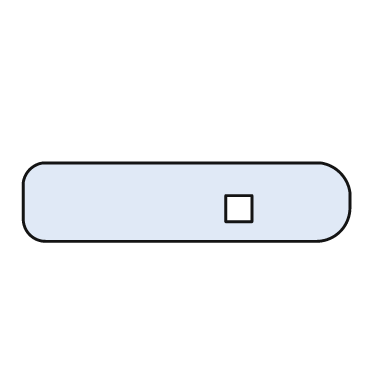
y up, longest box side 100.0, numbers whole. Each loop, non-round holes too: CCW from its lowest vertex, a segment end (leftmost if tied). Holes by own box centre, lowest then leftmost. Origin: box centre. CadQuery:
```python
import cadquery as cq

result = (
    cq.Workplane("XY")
    .moveTo(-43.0, -12.0)
    .lineTo(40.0, -12.0)
    .threePointArc((47.0, -9.0), (50.0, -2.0))
    .lineTo(50.0, 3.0)
    .threePointArc((47.0, 9.0), (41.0, 12.0))
    .lineTo(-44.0, 12.0)
    .threePointArc((-48.0, 10.0), (-50.0, 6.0))
    .lineTo(-50.0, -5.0)
    .threePointArc((-48.0, -10.0), (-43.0, -12.0))
    .close()
    .moveTo(12.0, -6.0)
    .lineTo(20.0, -6.0)
    .lineTo(20.0, 2.0)
    .lineTo(12.0, 2.0)
    .close()
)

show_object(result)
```